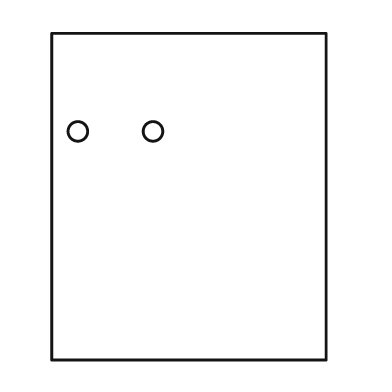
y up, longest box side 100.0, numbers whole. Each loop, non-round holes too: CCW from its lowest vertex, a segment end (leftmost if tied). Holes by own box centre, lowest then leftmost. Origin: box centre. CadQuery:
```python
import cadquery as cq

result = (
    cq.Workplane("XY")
    .moveTo(-42.0, -50.0)
    .lineTo(42.0, -50.0)
    .lineTo(42.0, 50.0)
    .lineTo(-42.0, 50.0)
    .close()
    .moveTo(-34.0, 20.0)
    .circle(3.0)
    .moveTo(-11.0, 20.0)
    .circle(3.0)
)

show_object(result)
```